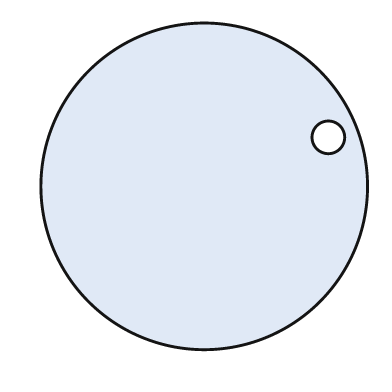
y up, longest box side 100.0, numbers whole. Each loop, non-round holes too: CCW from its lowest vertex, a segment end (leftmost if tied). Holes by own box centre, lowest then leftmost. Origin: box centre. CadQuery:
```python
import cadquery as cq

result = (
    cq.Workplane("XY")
    .moveTo(0.0, 0.0)
    .circle(50.0)
    .moveTo(38.0, 15.0)
    .circle(5.0)
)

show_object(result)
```